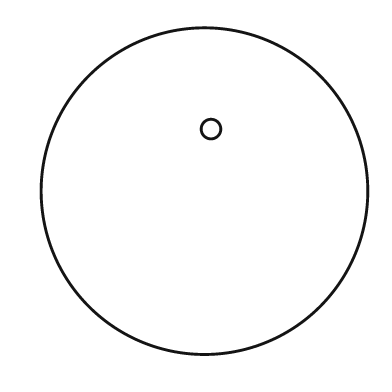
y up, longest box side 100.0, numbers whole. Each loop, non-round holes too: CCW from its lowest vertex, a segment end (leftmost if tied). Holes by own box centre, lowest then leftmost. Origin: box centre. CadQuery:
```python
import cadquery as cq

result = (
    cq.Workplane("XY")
    .moveTo(0.0, 0.0)
    .circle(50.0)
    .moveTo(2.0, 19.0)
    .circle(3.0)
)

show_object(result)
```